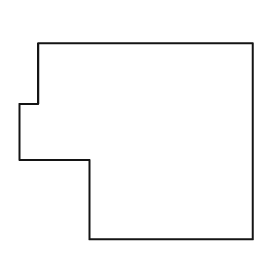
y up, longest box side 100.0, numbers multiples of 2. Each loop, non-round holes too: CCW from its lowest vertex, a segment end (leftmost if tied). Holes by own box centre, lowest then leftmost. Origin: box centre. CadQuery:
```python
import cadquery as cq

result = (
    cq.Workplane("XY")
    .moveTo(-20.0, -42.0)
    .lineTo(50.0, -42.0)
    .lineTo(50.0, 42.0)
    .lineTo(-42.0, 42.0)
    .lineTo(-42.0, 16.0)
    .lineTo(-50.0, 16.0)
    .lineTo(-50.0, -8.0)
    .lineTo(-20.0, -8.0)
    .close()
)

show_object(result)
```